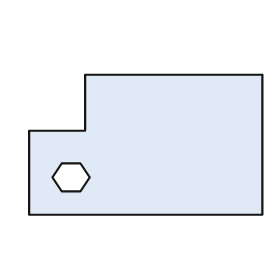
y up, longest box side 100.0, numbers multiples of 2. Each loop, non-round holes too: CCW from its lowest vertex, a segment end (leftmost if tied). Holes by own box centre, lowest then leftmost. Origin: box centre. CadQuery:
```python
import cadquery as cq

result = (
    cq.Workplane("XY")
    .moveTo(-50.0, -30.0)
    .lineTo(50.0, -30.0)
    .lineTo(50.0, 30.0)
    .lineTo(-26.0, 30.0)
    .lineTo(-26.0, 6.0)
    .lineTo(-50.0, 6.0)
    .close()
    .moveTo(-36.0, -20.0)
    .lineTo(-28.0, -20.0)
    .lineTo(-24.0, -14.0)
    .lineTo(-28.0, -8.0)
    .lineTo(-36.0, -8.0)
    .lineTo(-40.0, -14.0)
    .close()
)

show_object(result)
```